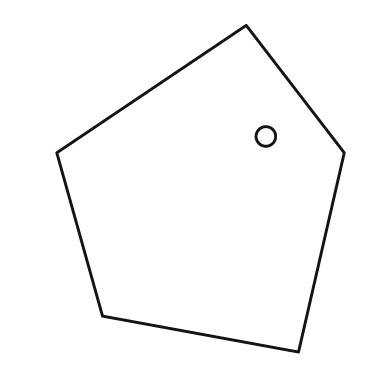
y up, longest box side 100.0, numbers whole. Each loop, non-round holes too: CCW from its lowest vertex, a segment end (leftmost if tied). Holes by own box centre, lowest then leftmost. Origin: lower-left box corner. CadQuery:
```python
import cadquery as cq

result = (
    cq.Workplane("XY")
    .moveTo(74.0, 0.0)
    .lineTo(88.0, 61.0)
    .lineTo(58.0, 100.0)
    .lineTo(0.0, 61.0)
    .lineTo(14.0, 11.0)
    .close()
    .moveTo(64.0, 66.0)
    .circle(3.0)
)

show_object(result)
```